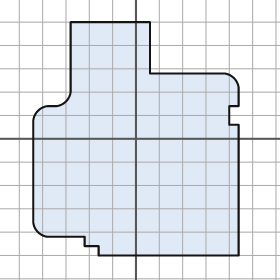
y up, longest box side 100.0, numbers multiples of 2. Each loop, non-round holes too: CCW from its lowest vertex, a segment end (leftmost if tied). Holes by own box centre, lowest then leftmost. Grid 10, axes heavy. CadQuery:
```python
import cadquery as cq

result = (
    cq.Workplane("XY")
    .moveTo(-16.0, -50.0)
    .lineTo(44.0, -50.0)
    .lineTo(44.0, 6.0)
    .lineTo(40.0, 6.0)
    .lineTo(40.0, 14.0)
    .lineTo(44.0, 14.0)
    .lineTo(44.0, 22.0)
    .threePointArc((42.0, 26.0), (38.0, 28.0))
    .lineTo(6.0, 28.0)
    .lineTo(6.0, 50.0)
    .lineTo(-28.0, 50.0)
    .lineTo(-28.0, 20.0)
    .threePointArc((-30.0, 16.0), (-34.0, 14.0))
    .lineTo(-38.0, 14.0)
    .threePointArc((-42.0, 12.0), (-44.0, 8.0))
    .lineTo(-44.0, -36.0)
    .threePointArc((-42.0, -40.0), (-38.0, -42.0))
    .lineTo(-22.0, -42.0)
    .lineTo(-22.0, -46.0)
    .lineTo(-16.0, -46.0)
    .close()
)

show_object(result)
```